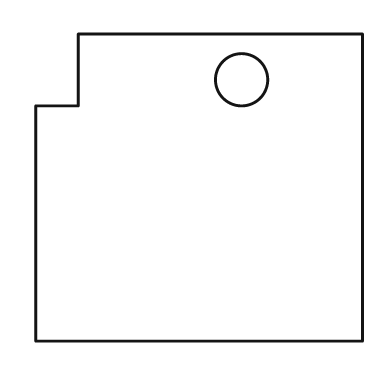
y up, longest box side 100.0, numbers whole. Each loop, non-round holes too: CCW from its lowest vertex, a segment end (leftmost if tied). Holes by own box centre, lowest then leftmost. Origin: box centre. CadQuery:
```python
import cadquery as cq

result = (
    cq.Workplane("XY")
    .moveTo(-50.0, -47.0)
    .lineTo(50.0, -47.0)
    .lineTo(50.0, 47.0)
    .lineTo(-37.0, 47.0)
    .lineTo(-37.0, 25.0)
    .lineTo(-50.0, 25.0)
    .close()
    .moveTo(13.0, 33.0)
    .circle(8.0)
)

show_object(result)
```